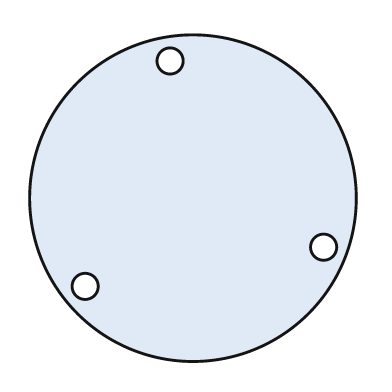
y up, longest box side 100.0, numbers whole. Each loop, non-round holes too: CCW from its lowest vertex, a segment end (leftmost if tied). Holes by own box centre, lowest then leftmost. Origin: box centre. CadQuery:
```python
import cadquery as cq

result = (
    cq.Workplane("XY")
    .moveTo(0.0, 0.0)
    .circle(50.0)
    .moveTo(-33.0, -27.0)
    .circle(4.0)
    .moveTo(40.0, -15.0)
    .circle(4.0)
    .moveTo(-7.0, 42.0)
    .circle(4.0)
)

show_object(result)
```